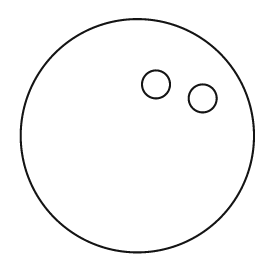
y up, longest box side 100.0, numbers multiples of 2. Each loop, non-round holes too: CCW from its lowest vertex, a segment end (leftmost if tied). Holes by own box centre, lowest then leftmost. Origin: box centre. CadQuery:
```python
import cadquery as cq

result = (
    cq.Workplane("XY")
    .moveTo(0.0, 0.0)
    .circle(50.0)
    .moveTo(28.0, 16.0)
    .circle(6.0)
    .moveTo(8.0, 22.0)
    .circle(6.0)
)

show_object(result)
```